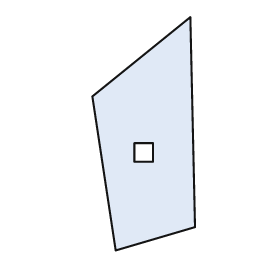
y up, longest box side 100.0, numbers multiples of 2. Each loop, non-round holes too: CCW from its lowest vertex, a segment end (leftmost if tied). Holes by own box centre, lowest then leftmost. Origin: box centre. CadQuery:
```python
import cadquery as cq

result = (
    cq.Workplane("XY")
    .moveTo(-12.0, -50.0)
    .lineTo(22.0, -40.0)
    .lineTo(20.0, 50.0)
    .lineTo(-22.0, 16.0)
    .close()
    .moveTo(-4.0, -12.0)
    .lineTo(4.0, -12.0)
    .lineTo(4.0, -4.0)
    .lineTo(-4.0, -4.0)
    .close()
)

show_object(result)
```